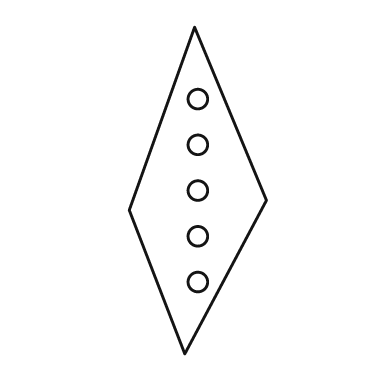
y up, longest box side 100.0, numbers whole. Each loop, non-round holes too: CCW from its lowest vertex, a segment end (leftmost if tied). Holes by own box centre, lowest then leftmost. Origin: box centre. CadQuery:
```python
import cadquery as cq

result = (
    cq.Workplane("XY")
    .moveTo(-4.0, -50.0)
    .lineTo(21.0, -3.0)
    .lineTo(-1.0, 50.0)
    .lineTo(-21.0, -6.0)
    .close()
    .moveTo(0.0, -28.0)
    .circle(3.0)
    .moveTo(0.0, -14.0)
    .circle(3.0)
    .moveTo(0.0, 0.0)
    .circle(3.0)
    .moveTo(0.0, 14.0)
    .circle(3.0)
    .moveTo(0.0, 28.0)
    .circle(3.0)
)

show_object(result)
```